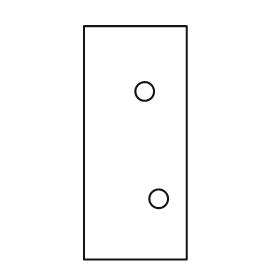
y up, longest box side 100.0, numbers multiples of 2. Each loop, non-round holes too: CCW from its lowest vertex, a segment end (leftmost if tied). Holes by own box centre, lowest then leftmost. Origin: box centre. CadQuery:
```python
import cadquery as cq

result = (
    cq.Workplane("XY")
    .moveTo(-22.0, -50.0)
    .lineTo(22.0, -50.0)
    .lineTo(22.0, 50.0)
    .lineTo(-22.0, 50.0)
    .close()
    .moveTo(10.0, -24.0)
    .circle(4.0)
    .moveTo(4.0, 22.0)
    .circle(4.0)
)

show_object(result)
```